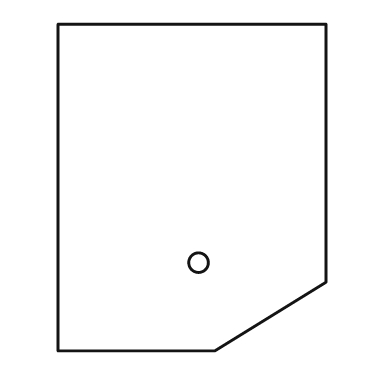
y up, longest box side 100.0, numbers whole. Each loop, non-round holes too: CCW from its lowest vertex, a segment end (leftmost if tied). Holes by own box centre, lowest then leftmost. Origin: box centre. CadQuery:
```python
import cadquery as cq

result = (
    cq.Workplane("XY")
    .moveTo(-41.0, -50.0)
    .lineTo(7.0, -50.0)
    .lineTo(41.0, -29.0)
    .lineTo(41.0, 50.0)
    .lineTo(-41.0, 50.0)
    .close()
    .moveTo(2.0, -23.0)
    .circle(3.0)
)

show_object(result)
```